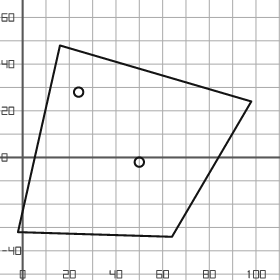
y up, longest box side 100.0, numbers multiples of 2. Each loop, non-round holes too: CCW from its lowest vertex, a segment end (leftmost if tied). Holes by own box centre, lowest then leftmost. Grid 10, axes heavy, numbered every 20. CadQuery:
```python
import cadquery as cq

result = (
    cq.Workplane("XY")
    .moveTo(64.0, -34.0)
    .lineTo(98.0, 24.0)
    .lineTo(16.0, 48.0)
    .lineTo(-2.0, -32.0)
    .close()
    .moveTo(50.0, -2.0)
    .circle(2.0)
    .moveTo(24.0, 28.0)
    .circle(2.0)
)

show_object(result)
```